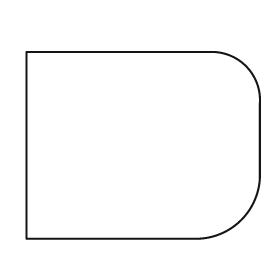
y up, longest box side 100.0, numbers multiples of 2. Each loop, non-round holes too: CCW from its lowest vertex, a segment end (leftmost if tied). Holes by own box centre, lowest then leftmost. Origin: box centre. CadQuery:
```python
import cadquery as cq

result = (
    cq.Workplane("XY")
    .moveTo(-50.0, -40.0)
    .lineTo(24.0, -40.0)
    .threePointArc((42.0, -32.0), (50.0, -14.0))
    .lineTo(50.0, 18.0)
    .threePointArc((44.0, 34.0), (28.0, 40.0))
    .lineTo(-50.0, 40.0)
    .close()
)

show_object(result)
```